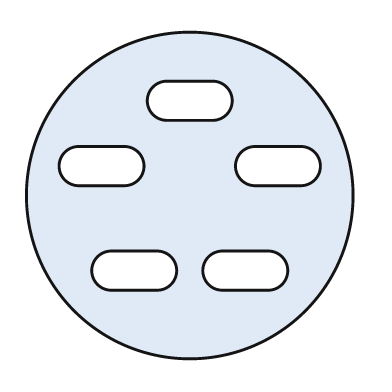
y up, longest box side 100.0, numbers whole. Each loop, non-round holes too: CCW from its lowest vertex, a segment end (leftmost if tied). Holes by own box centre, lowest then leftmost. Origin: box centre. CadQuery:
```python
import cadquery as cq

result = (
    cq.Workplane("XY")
    .moveTo(0.0, 0.0)
    .circle(50.0)
    .moveTo(-24.0, -29.0)
    .lineTo(-10.0, -29.0)
    .threePointArc((-4.0, -23.0), (-10.0, -17.0))
    .lineTo(-24.0, -17.0)
    .threePointArc((-30.0, -23.0), (-24.0, -29.0))
    .close()
    .moveTo(10.0, -29.0)
    .lineTo(24.0, -29.0)
    .threePointArc((30.0, -23.0), (24.0, -17.0))
    .lineTo(10.0, -17.0)
    .threePointArc((4.0, -23.0), (10.0, -29.0))
    .close()
    .moveTo(-34.0, 3.0)
    .lineTo(-20.0, 3.0)
    .threePointArc((-14.0, 9.0), (-20.0, 15.0))
    .lineTo(-34.0, 15.0)
    .threePointArc((-40.0, 9.0), (-34.0, 3.0))
    .close()
    .moveTo(20.0, 3.0)
    .lineTo(34.0, 3.0)
    .threePointArc((40.0, 9.0), (34.0, 15.0))
    .lineTo(20.0, 15.0)
    .threePointArc((14.0, 9.0), (20.0, 3.0))
    .close()
    .moveTo(-7.0, 23.0)
    .lineTo(7.0, 23.0)
    .threePointArc((13.0, 29.0), (7.0, 35.0))
    .lineTo(-7.0, 35.0)
    .threePointArc((-13.0, 29.0), (-7.0, 23.0))
    .close()
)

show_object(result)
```